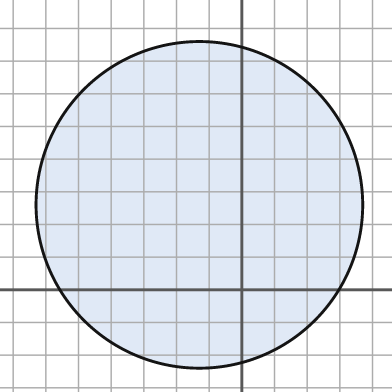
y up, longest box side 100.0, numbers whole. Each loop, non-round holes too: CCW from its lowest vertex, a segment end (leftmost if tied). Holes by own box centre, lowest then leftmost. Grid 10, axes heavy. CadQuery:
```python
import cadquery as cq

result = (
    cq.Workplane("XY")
    .moveTo(-13.0, 26.0)
    .circle(50.0)
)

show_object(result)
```